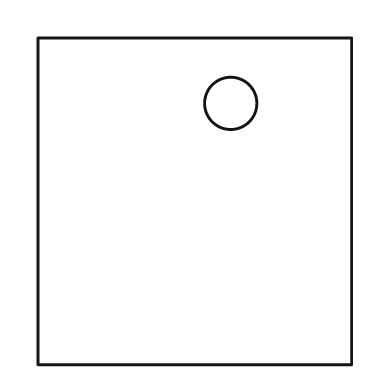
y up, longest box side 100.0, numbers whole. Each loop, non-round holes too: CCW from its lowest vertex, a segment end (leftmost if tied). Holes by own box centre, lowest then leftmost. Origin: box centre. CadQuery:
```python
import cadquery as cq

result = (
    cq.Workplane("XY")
    .moveTo(-48.0, -50.0)
    .lineTo(48.0, -50.0)
    .lineTo(48.0, 50.0)
    .lineTo(-48.0, 50.0)
    .close()
    .moveTo(11.0, 30.0)
    .circle(8.0)
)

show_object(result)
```